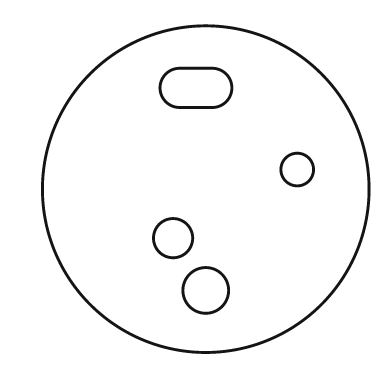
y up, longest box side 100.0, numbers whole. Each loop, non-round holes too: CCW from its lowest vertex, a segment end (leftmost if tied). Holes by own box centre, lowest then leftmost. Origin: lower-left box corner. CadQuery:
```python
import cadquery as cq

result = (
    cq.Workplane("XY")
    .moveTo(50.0, 50.0)
    .circle(50.0)
    .moveTo(50.0, 19.0)
    .circle(7.0)
    .moveTo(40.0, 35.0)
    .circle(6.0)
    .moveTo(78.0, 56.0)
    .circle(5.0)
    .moveTo(42.0, 75.0)
    .lineTo(52.0, 75.0)
    .threePointArc((58.0, 81.0), (52.0, 87.0))
    .lineTo(42.0, 87.0)
    .threePointArc((36.0, 81.0), (42.0, 75.0))
    .close()
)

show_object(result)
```